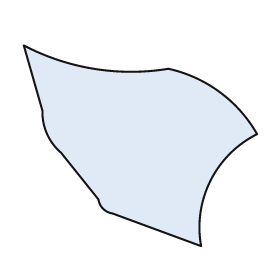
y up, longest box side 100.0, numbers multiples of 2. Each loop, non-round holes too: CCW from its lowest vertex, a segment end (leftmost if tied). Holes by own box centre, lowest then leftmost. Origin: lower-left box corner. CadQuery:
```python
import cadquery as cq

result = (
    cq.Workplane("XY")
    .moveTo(76.0, 0.0)
    .threePointArc((80.0, 28.0), (100.0, 48.0))
    .threePointArc((84.0, 66.0), (62.0, 76.0))
    .threePointArc((30.0, 76.0), (0.0, 86.0))
    .lineTo(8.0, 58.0)
    .threePointArc((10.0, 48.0), (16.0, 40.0))
    .lineTo(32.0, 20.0)
    .threePointArc((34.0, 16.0), (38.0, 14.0))
    .close()
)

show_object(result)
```